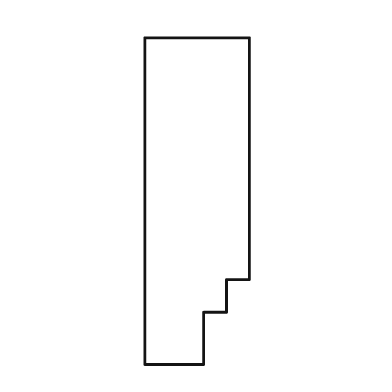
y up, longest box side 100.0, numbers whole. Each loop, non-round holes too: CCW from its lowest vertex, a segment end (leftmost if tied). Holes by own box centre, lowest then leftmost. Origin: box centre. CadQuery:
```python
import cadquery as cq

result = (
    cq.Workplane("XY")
    .moveTo(-16.0, -50.0)
    .lineTo(2.0, -50.0)
    .lineTo(2.0, -34.0)
    .lineTo(9.0, -34.0)
    .lineTo(9.0, -24.0)
    .lineTo(16.0, -24.0)
    .lineTo(16.0, 50.0)
    .lineTo(-16.0, 50.0)
    .close()
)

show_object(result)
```